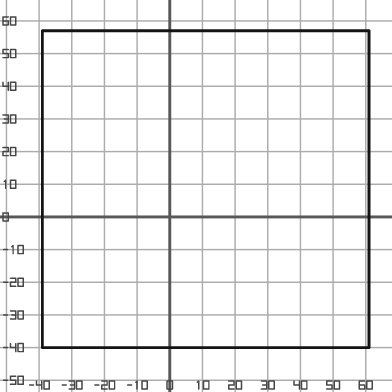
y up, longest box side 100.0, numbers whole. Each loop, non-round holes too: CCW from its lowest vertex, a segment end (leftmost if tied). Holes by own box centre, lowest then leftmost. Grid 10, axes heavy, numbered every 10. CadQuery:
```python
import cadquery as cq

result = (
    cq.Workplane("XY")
    .moveTo(-39.0, -40.0)
    .lineTo(61.0, -40.0)
    .lineTo(61.0, 57.0)
    .lineTo(-39.0, 57.0)
    .close()
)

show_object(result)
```